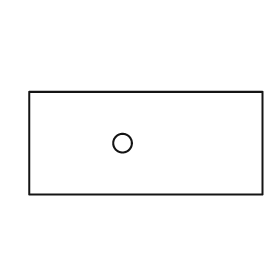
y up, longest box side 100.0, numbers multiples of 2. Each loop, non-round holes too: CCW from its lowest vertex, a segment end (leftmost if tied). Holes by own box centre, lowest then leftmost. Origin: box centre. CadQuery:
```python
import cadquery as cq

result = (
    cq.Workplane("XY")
    .moveTo(-50.0, -22.0)
    .lineTo(50.0, -22.0)
    .lineTo(50.0, 22.0)
    .lineTo(-50.0, 22.0)
    .close()
    .moveTo(-10.0, 0.0)
    .circle(4.0)
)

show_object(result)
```